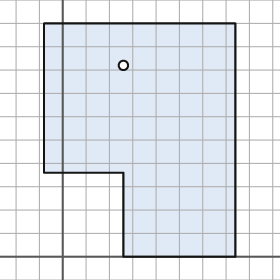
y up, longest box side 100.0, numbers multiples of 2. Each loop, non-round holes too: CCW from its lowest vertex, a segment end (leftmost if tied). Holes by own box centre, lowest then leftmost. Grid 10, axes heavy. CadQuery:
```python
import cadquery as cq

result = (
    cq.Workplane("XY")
    .moveTo(26.0, 0.0)
    .lineTo(74.0, 0.0)
    .lineTo(74.0, 100.0)
    .lineTo(-8.0, 100.0)
    .lineTo(-8.0, 36.0)
    .lineTo(26.0, 36.0)
    .close()
    .moveTo(26.0, 82.0)
    .circle(2.0)
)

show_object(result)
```